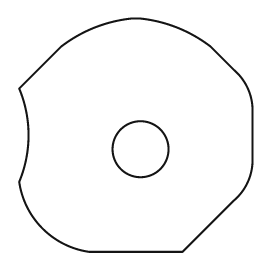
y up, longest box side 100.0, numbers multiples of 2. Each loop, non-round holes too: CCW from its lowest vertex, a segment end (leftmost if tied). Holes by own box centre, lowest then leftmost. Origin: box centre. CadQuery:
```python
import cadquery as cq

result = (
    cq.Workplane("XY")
    .moveTo(-20.0, -50.0)
    .lineTo(20.0, -50.0)
    .lineTo(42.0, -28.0)
    .threePointArc((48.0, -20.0), (50.0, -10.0))
    .lineTo(50.0, 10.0)
    .threePointArc((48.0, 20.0), (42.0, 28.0))
    .lineTo(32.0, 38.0)
    .threePointArc((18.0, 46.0), (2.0, 50.0))
    .lineTo(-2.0, 50.0)
    .threePointArc((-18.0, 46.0), (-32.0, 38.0))
    .lineTo(-50.0, 20.0)
    .threePointArc((-46.0, 0.0), (-50.0, -20.0))
    .threePointArc((-40.0, -40.0), (-20.0, -50.0))
    .close()
    .moveTo(2.0, -6.0)
    .circle(12.0)
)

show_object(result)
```